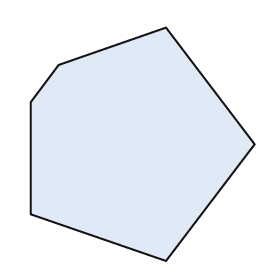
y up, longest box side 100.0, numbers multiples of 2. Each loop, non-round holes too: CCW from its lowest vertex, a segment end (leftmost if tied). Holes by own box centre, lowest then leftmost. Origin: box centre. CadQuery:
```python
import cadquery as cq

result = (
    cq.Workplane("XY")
    .moveTo(10.0, -50.0)
    .lineTo(48.0, 0.0)
    .lineTo(10.0, 50.0)
    .lineTo(-36.0, 34.0)
    .lineTo(-48.0, 18.0)
    .lineTo(-48.0, -30.0)
    .close()
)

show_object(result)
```